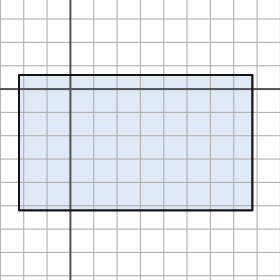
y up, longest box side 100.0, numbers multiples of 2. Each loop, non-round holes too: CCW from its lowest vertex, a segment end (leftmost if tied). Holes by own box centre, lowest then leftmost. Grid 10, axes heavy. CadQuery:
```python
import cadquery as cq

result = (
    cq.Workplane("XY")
    .moveTo(-22.0, -52.0)
    .lineTo(78.0, -52.0)
    .lineTo(78.0, 6.0)
    .lineTo(-22.0, 6.0)
    .close()
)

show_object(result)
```